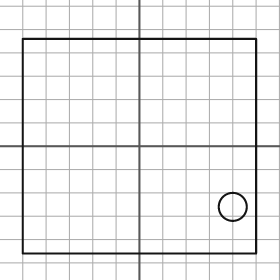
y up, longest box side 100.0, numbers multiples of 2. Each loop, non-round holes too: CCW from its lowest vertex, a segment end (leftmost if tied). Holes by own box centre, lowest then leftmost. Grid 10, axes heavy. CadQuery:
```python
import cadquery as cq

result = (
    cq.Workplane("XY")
    .moveTo(-50.0, -46.0)
    .lineTo(50.0, -46.0)
    .lineTo(50.0, 46.0)
    .lineTo(-50.0, 46.0)
    .close()
    .moveTo(40.0, -26.0)
    .circle(6.0)
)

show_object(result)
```